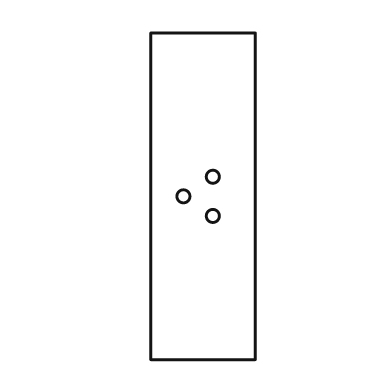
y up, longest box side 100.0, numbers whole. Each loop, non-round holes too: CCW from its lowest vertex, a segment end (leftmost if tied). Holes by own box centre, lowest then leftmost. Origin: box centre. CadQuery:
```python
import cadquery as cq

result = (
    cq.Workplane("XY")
    .moveTo(-16.0, -50.0)
    .lineTo(16.0, -50.0)
    .lineTo(16.0, 50.0)
    .lineTo(-16.0, 50.0)
    .close()
    .moveTo(3.0, -6.0)
    .circle(2.0)
    .moveTo(-6.0, 0.0)
    .circle(2.0)
    .moveTo(3.0, 6.0)
    .circle(2.0)
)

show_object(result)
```